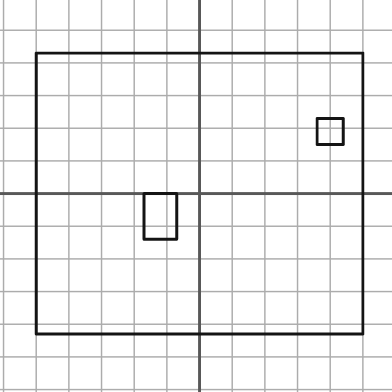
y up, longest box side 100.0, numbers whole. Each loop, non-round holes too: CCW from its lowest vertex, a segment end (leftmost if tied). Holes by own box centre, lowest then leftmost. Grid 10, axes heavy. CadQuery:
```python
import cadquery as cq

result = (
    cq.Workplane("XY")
    .moveTo(-50.0, -43.0)
    .lineTo(50.0, -43.0)
    .lineTo(50.0, 43.0)
    .lineTo(-50.0, 43.0)
    .close()
    .moveTo(-17.0, -14.0)
    .lineTo(-7.0, -14.0)
    .lineTo(-7.0, 0.0)
    .lineTo(-17.0, 0.0)
    .close()
    .moveTo(36.0, 15.0)
    .lineTo(44.0, 15.0)
    .lineTo(44.0, 23.0)
    .lineTo(36.0, 23.0)
    .close()
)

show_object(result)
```